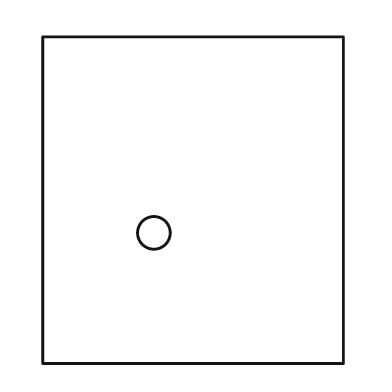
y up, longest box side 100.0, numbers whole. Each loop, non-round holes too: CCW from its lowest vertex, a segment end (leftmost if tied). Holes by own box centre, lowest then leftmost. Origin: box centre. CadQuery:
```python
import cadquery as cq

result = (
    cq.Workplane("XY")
    .moveTo(-46.0, -50.0)
    .lineTo(46.0, -50.0)
    .lineTo(46.0, 50.0)
    .lineTo(-46.0, 50.0)
    .close()
    .moveTo(-12.0, -10.0)
    .circle(5.0)
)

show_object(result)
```